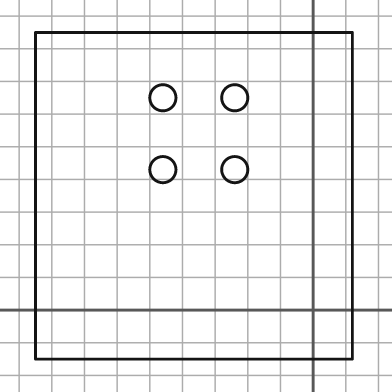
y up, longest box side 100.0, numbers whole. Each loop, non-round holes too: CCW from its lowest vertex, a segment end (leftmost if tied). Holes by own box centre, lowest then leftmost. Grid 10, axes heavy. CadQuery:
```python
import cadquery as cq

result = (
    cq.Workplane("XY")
    .moveTo(-85.0, -15.0)
    .lineTo(12.0, -15.0)
    .lineTo(12.0, 85.0)
    .lineTo(-85.0, 85.0)
    .close()
    .moveTo(-46.0, 43.0)
    .circle(4.0)
    .moveTo(-24.0, 43.0)
    .circle(4.0)
    .moveTo(-46.0, 65.0)
    .circle(4.0)
    .moveTo(-24.0, 65.0)
    .circle(4.0)
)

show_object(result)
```